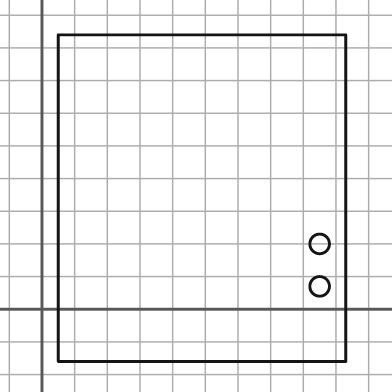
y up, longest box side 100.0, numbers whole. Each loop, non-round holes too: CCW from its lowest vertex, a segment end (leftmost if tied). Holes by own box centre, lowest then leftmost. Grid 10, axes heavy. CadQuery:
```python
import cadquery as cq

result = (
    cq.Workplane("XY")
    .moveTo(5.0, -16.0)
    .lineTo(93.0, -16.0)
    .lineTo(93.0, 84.0)
    .lineTo(5.0, 84.0)
    .close()
    .moveTo(85.0, 7.0)
    .circle(3.0)
    .moveTo(85.0, 20.0)
    .circle(3.0)
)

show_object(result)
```